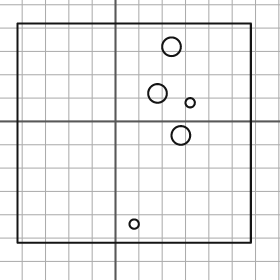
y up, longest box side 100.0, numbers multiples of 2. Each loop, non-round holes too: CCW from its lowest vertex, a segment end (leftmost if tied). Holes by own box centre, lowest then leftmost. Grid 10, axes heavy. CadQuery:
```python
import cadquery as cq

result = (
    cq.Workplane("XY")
    .moveTo(-42.0, -52.0)
    .lineTo(58.0, -52.0)
    .lineTo(58.0, 42.0)
    .lineTo(-42.0, 42.0)
    .close()
    .moveTo(8.0, -44.0)
    .circle(2.0)
    .moveTo(28.0, -6.0)
    .circle(4.0)
    .moveTo(32.0, 8.0)
    .circle(2.0)
    .moveTo(18.0, 12.0)
    .circle(4.0)
    .moveTo(24.0, 32.0)
    .circle(4.0)
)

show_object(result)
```